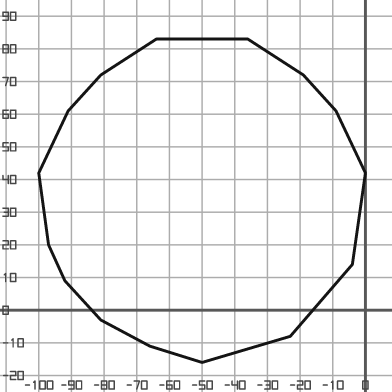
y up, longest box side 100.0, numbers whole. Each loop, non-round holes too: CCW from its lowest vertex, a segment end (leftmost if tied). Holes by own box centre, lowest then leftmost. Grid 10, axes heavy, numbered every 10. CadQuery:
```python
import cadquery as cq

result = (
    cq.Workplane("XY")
    .moveTo(-50.0, -16.0)
    .lineTo(-23.0, -8.0)
    .lineTo(-4.0, 14.0)
    .lineTo(0.0, 42.0)
    .lineTo(-9.0, 61.0)
    .lineTo(-19.0, 72.0)
    .lineTo(-36.0, 83.0)
    .lineTo(-64.0, 83.0)
    .lineTo(-81.0, 72.0)
    .lineTo(-91.0, 61.0)
    .lineTo(-100.0, 42.0)
    .lineTo(-97.0, 20.0)
    .lineTo(-92.0, 9.0)
    .lineTo(-81.0, -3.0)
    .lineTo(-66.0, -11.0)
    .close()
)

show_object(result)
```